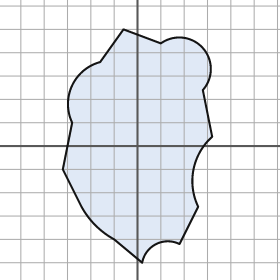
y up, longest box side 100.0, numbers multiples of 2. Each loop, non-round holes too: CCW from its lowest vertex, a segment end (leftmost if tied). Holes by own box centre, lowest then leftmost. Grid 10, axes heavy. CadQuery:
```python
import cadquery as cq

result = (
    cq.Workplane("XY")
    .moveTo(2.0, -50.0)
    .threePointArc((8.0, -42.0), (18.0, -42.0))
    .lineTo(26.0, -26.0)
    .threePointArc((24.0, -10.0), (32.0, 4.0))
    .lineTo(28.0, 24.0)
    .threePointArc((28.0, 42.0), (10.0, 44.0))
    .lineTo(-6.0, 50.0)
    .lineTo(-16.0, 36.0)
    .threePointArc((-28.0, 26.0), (-28.0, 10.0))
    .lineTo(-32.0, -10.0)
    .lineTo(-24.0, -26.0)
    .threePointArc((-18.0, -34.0), (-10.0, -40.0))
    .close()
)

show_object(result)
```